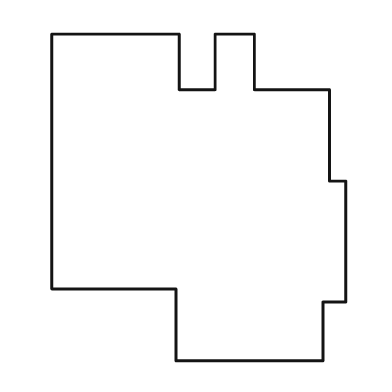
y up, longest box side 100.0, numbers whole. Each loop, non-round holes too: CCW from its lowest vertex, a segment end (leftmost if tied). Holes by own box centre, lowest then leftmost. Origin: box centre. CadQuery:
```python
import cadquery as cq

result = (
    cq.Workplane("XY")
    .moveTo(-7.0, -50.0)
    .lineTo(38.0, -50.0)
    .lineTo(38.0, -32.0)
    .lineTo(45.0, -32.0)
    .lineTo(45.0, 5.0)
    .lineTo(40.0, 5.0)
    .lineTo(40.0, 33.0)
    .lineTo(17.0, 33.0)
    .lineTo(17.0, 50.0)
    .lineTo(5.0, 50.0)
    .lineTo(5.0, 33.0)
    .lineTo(-6.0, 33.0)
    .lineTo(-6.0, 50.0)
    .lineTo(-45.0, 50.0)
    .lineTo(-45.0, -28.0)
    .lineTo(-7.0, -28.0)
    .close()
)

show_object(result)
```